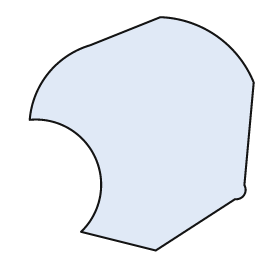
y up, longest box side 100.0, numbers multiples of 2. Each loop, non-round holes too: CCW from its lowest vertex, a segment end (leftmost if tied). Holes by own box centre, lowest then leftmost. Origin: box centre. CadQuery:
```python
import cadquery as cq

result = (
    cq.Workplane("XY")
    .moveTo(6.0, -50.0)
    .lineTo(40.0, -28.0)
    .threePointArc((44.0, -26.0), (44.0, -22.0))
    .lineTo(48.0, 22.0)
    .threePointArc((32.0, 42.0), (8.0, 50.0))
    .lineTo(-22.0, 38.0)
    .threePointArc((-40.0, 26.0), (-48.0, 6.0))
    .threePointArc((-20.0, -10.0), (-26.0, -42.0))
    .close()
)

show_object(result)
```